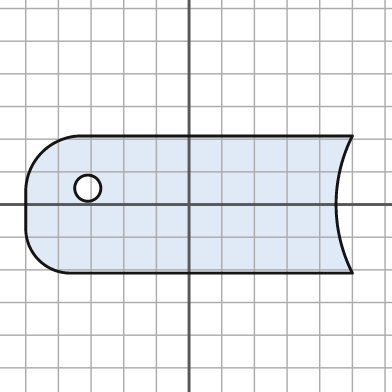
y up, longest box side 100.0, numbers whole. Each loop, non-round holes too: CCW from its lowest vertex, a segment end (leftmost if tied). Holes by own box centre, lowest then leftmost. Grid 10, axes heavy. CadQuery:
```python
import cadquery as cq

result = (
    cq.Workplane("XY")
    .moveTo(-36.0, -21.0)
    .lineTo(50.0, -21.0)
    .threePointArc((45.0, 0.0), (50.0, 21.0))
    .lineTo(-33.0, 21.0)
    .threePointArc((-45.0, 16.0), (-50.0, 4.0))
    .lineTo(-50.0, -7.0)
    .threePointArc((-46.0, -17.0), (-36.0, -21.0))
    .close()
    .moveTo(-31.0, 5.0)
    .circle(4.0)
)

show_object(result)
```